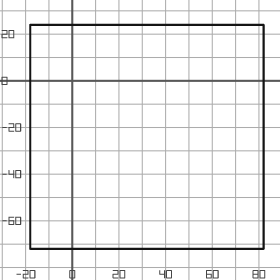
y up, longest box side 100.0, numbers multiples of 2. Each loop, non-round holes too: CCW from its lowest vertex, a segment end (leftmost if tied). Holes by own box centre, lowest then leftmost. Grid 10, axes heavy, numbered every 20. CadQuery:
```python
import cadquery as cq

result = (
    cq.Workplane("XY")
    .moveTo(-18.0, -72.0)
    .lineTo(82.0, -72.0)
    .lineTo(82.0, 24.0)
    .lineTo(-18.0, 24.0)
    .close()
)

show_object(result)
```